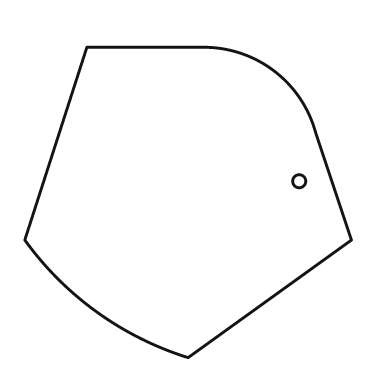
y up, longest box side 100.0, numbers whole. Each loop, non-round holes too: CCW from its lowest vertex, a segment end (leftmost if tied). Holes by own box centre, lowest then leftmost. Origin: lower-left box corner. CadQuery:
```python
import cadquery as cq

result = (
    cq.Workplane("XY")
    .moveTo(50.0, 0.0)
    .lineTo(100.0, 36.0)
    .lineTo(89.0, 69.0)
    .threePointArc((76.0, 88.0), (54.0, 95.0))
    .lineTo(19.0, 95.0)
    .lineTo(0.0, 36.0)
    .threePointArc((22.0, 14.0), (50.0, 0.0))
    .close()
    .moveTo(84.0, 54.0)
    .circle(2.0)
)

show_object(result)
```